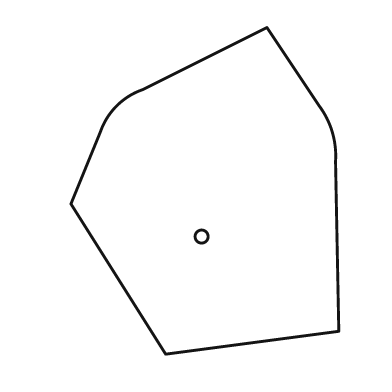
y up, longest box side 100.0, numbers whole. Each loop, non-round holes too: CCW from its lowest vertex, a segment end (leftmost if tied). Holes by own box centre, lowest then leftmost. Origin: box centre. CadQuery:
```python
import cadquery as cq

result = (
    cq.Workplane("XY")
    .moveTo(-12.0, -50.0)
    .lineTo(41.0, -43.0)
    .lineTo(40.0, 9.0)
    .threePointArc((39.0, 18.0), (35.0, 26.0))
    .lineTo(19.0, 50.0)
    .lineTo(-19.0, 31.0)
    .threePointArc((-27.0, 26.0), (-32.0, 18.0))
    .lineTo(-41.0, -4.0)
    .close()
    .moveTo(-1.0, -14.0)
    .circle(2.0)
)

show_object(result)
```